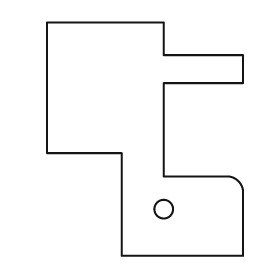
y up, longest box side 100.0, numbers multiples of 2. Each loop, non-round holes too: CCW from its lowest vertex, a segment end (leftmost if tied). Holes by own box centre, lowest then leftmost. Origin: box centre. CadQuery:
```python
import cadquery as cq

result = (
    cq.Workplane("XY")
    .moveTo(-10.0, -50.0)
    .lineTo(42.0, -50.0)
    .lineTo(42.0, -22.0)
    .threePointArc((40.0, -18.0), (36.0, -16.0))
    .lineTo(8.0, -16.0)
    .lineTo(8.0, 24.0)
    .lineTo(42.0, 24.0)
    .lineTo(42.0, 36.0)
    .lineTo(8.0, 36.0)
    .lineTo(8.0, 50.0)
    .lineTo(-42.0, 50.0)
    .lineTo(-42.0, -6.0)
    .lineTo(-10.0, -6.0)
    .close()
    .moveTo(8.0, -30.0)
    .circle(4.0)
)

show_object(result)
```